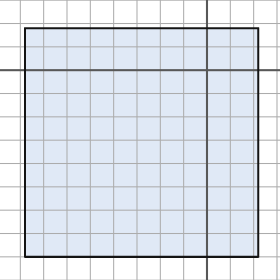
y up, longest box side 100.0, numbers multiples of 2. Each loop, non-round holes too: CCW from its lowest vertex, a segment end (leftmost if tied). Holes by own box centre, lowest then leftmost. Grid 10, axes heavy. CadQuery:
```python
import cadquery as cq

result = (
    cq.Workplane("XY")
    .moveTo(-78.0, -80.0)
    .lineTo(22.0, -80.0)
    .lineTo(22.0, 18.0)
    .lineTo(-78.0, 18.0)
    .close()
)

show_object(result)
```